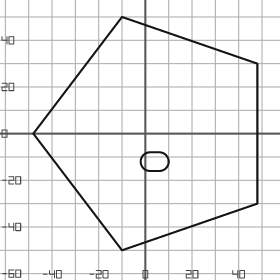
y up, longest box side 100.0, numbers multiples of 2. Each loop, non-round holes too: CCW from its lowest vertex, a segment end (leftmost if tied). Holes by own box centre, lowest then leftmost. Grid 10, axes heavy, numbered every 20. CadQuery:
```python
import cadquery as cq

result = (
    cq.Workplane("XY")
    .moveTo(-10.0, -50.0)
    .lineTo(48.0, -30.0)
    .lineTo(48.0, 30.0)
    .lineTo(-10.0, 50.0)
    .lineTo(-48.0, 0.0)
    .close()
    .moveTo(2.0, -16.0)
    .lineTo(6.0, -16.0)
    .threePointArc((10.0, -12.0), (6.0, -8.0))
    .lineTo(2.0, -8.0)
    .threePointArc((-2.0, -12.0), (2.0, -16.0))
    .close()
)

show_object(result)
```